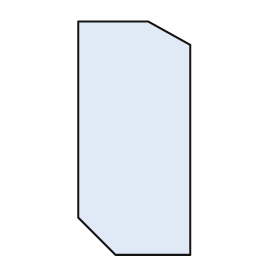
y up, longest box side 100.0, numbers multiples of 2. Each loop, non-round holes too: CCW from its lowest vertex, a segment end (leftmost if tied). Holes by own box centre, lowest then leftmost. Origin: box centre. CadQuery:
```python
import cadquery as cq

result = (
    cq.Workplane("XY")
    .moveTo(-8.0, -50.0)
    .lineTo(24.0, -50.0)
    .lineTo(24.0, 40.0)
    .lineTo(6.0, 50.0)
    .lineTo(-24.0, 50.0)
    .lineTo(-24.0, -34.0)
    .close()
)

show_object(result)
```